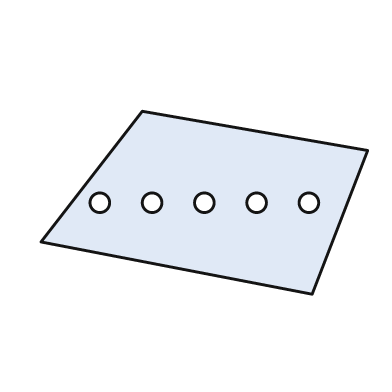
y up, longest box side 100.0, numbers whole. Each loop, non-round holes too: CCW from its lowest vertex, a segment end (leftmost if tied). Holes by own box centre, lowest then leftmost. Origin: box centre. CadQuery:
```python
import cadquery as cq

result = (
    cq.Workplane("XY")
    .moveTo(33.0, -28.0)
    .lineTo(50.0, 16.0)
    .lineTo(-19.0, 28.0)
    .lineTo(-50.0, -12.0)
    .close()
    .moveTo(-32.0, 0.0)
    .circle(3.0)
    .moveTo(-16.0, 0.0)
    .circle(3.0)
    .moveTo(0.0, 0.0)
    .circle(3.0)
    .moveTo(16.0, 0.0)
    .circle(3.0)
    .moveTo(32.0, 0.0)
    .circle(3.0)
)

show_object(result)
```